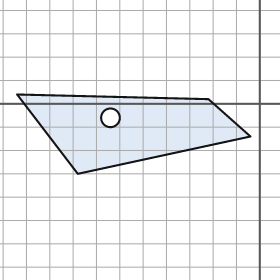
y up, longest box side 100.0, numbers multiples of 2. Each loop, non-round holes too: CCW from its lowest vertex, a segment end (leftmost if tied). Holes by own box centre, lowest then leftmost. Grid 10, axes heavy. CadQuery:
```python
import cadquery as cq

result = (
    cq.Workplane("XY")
    .moveTo(-78.0, -30.0)
    .lineTo(-4.0, -14.0)
    .lineTo(-22.0, 2.0)
    .lineTo(-104.0, 4.0)
    .close()
    .moveTo(-64.0, -6.0)
    .circle(4.0)
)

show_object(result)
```